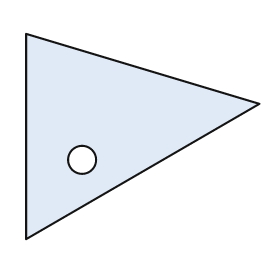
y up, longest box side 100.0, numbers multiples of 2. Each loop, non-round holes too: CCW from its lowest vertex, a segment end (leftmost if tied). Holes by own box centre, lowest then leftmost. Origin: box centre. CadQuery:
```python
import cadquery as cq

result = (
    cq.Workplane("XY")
    .moveTo(-50.0, -44.0)
    .lineTo(50.0, 14.0)
    .lineTo(-50.0, 44.0)
    .close()
    .moveTo(-26.0, -10.0)
    .circle(6.0)
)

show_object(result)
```